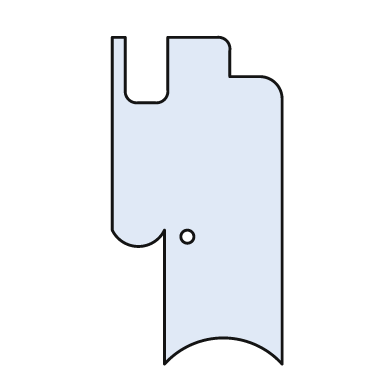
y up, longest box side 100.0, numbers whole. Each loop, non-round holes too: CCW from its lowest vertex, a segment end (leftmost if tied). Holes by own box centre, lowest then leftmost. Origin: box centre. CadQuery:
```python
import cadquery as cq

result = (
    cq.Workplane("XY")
    .moveTo(-10.0, -50.0)
    .threePointArc((8.0, -42.0), (26.0, -50.0))
    .lineTo(26.0, 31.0)
    .threePointArc((24.0, 36.0), (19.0, 38.0))
    .lineTo(10.0, 38.0)
    .lineTo(10.0, 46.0)
    .threePointArc((9.0, 49.0), (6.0, 50.0))
    .lineTo(-9.0, 50.0)
    .lineTo(-9.0, 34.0)
    .threePointArc((-10.0, 31.0), (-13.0, 30.0))
    .lineTo(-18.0, 30.0)
    .threePointArc((-21.0, 31.0), (-22.0, 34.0))
    .lineTo(-22.0, 50.0)
    .lineTo(-26.0, 50.0)
    .lineTo(-26.0, -9.0)
    .threePointArc((-18.0, -14.0), (-10.0, -9.0))
    .close()
    .moveTo(-3.0, -11.0)
    .circle(2.0)
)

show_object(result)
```